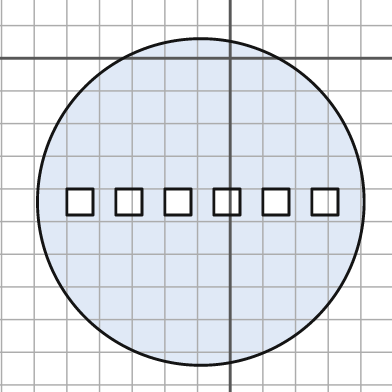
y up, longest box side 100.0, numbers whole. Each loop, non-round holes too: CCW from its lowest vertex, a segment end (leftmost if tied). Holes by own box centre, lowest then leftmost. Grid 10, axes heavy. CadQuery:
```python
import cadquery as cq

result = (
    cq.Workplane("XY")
    .moveTo(-9.0, -44.0)
    .circle(50.0)
    .moveTo(-50.0, -48.0)
    .lineTo(-42.0, -48.0)
    .lineTo(-42.0, -40.0)
    .lineTo(-50.0, -40.0)
    .close()
    .moveTo(-35.0, -48.0)
    .lineTo(-27.0, -48.0)
    .lineTo(-27.0, -40.0)
    .lineTo(-35.0, -40.0)
    .close()
    .moveTo(-20.0, -48.0)
    .lineTo(-12.0, -48.0)
    .lineTo(-12.0, -40.0)
    .lineTo(-20.0, -40.0)
    .close()
    .moveTo(-5.0, -48.0)
    .lineTo(3.0, -48.0)
    .lineTo(3.0, -40.0)
    .lineTo(-5.0, -40.0)
    .close()
    .moveTo(10.0, -48.0)
    .lineTo(18.0, -48.0)
    .lineTo(18.0, -40.0)
    .lineTo(10.0, -40.0)
    .close()
    .moveTo(25.0, -48.0)
    .lineTo(33.0, -48.0)
    .lineTo(33.0, -40.0)
    .lineTo(25.0, -40.0)
    .close()
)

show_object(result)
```